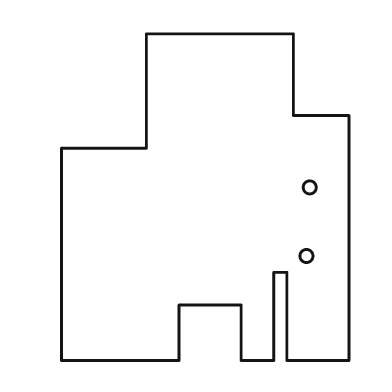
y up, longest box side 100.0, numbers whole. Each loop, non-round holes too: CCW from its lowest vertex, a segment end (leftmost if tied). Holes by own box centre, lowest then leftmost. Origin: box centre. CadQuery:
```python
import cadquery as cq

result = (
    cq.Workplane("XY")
    .moveTo(-44.0, -50.0)
    .lineTo(-8.0, -50.0)
    .lineTo(-8.0, -33.0)
    .lineTo(11.0, -33.0)
    .lineTo(11.0, -50.0)
    .lineTo(21.0, -50.0)
    .lineTo(21.0, -23.0)
    .lineTo(25.0, -23.0)
    .lineTo(25.0, -50.0)
    .lineTo(44.0, -50.0)
    .lineTo(44.0, 25.0)
    .lineTo(27.0, 25.0)
    .lineTo(27.0, 50.0)
    .lineTo(-18.0, 50.0)
    .lineTo(-18.0, 15.0)
    .lineTo(-44.0, 15.0)
    .close()
    .moveTo(31.0, -18.0)
    .circle(2.0)
    .moveTo(32.0, 3.0)
    .circle(2.0)
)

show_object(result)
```